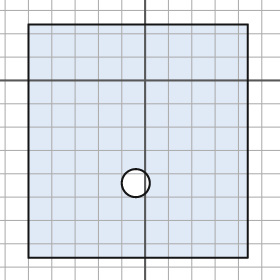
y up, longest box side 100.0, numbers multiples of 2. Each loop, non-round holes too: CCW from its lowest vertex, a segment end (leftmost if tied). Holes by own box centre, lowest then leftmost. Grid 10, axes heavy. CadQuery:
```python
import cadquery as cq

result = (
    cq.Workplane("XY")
    .moveTo(-50.0, -76.0)
    .lineTo(44.0, -76.0)
    .lineTo(44.0, 24.0)
    .lineTo(-50.0, 24.0)
    .close()
    .moveTo(-4.0, -44.0)
    .circle(6.0)
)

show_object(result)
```